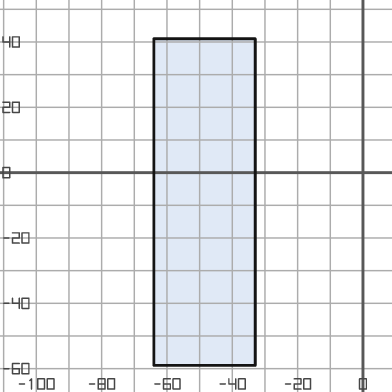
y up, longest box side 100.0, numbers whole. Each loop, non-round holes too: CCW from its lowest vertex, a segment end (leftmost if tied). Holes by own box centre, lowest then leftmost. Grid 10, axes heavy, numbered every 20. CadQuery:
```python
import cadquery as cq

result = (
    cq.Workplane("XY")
    .moveTo(-64.0, -59.0)
    .lineTo(-33.0, -59.0)
    .lineTo(-33.0, 41.0)
    .lineTo(-64.0, 41.0)
    .close()
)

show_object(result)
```